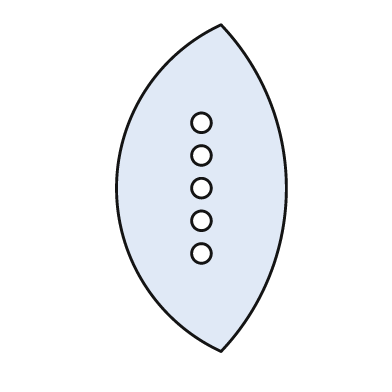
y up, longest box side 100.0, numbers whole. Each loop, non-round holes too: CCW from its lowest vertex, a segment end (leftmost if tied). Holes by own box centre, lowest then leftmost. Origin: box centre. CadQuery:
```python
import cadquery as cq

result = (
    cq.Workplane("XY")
    .moveTo(6.0, -50.0)
    .threePointArc((26.0, 0.0), (6.0, 50.0))
    .threePointArc((-26.0, 0.0), (6.0, -50.0))
    .close()
    .moveTo(0.0, -20.0)
    .circle(3.0)
    .moveTo(0.0, -10.0)
    .circle(3.0)
    .moveTo(0.0, 0.0)
    .circle(3.0)
    .moveTo(0.0, 10.0)
    .circle(3.0)
    .moveTo(0.0, 20.0)
    .circle(3.0)
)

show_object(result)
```